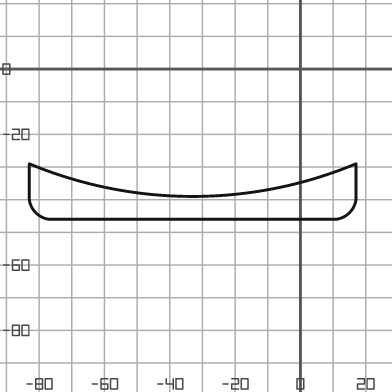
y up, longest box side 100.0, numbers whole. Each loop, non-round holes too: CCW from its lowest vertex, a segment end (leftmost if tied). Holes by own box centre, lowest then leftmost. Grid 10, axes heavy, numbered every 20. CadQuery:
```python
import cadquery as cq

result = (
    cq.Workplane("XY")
    .moveTo(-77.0, -46.0)
    .lineTo(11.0, -46.0)
    .threePointArc((15.0, -44.0), (17.0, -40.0))
    .lineTo(17.0, -29.0)
    .threePointArc((-33.0, -39.0), (-83.0, -29.0))
    .lineTo(-83.0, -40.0)
    .threePointArc((-81.0, -44.0), (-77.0, -46.0))
    .close()
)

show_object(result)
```